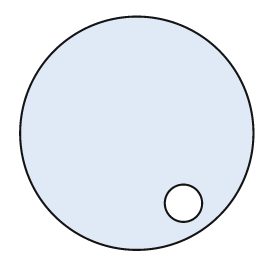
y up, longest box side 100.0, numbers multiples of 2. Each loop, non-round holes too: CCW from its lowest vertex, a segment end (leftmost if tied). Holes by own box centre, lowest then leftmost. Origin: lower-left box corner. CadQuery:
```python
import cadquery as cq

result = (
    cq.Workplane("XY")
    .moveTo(50.0, 50.0)
    .circle(50.0)
    .moveTo(70.0, 20.0)
    .circle(8.0)
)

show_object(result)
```